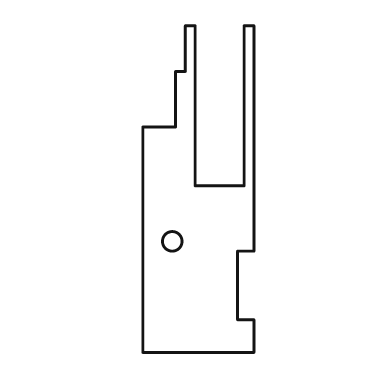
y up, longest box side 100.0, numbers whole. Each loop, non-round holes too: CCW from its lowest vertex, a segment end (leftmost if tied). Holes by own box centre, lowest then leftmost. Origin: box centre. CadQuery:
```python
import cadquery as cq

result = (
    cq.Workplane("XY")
    .moveTo(-17.0, -50.0)
    .lineTo(17.0, -50.0)
    .lineTo(17.0, -40.0)
    .lineTo(12.0, -40.0)
    .lineTo(12.0, -19.0)
    .lineTo(17.0, -19.0)
    .lineTo(17.0, 50.0)
    .lineTo(14.0, 50.0)
    .lineTo(14.0, 1.0)
    .lineTo(-1.0, 1.0)
    .lineTo(-1.0, 50.0)
    .lineTo(-4.0, 50.0)
    .lineTo(-4.0, 36.0)
    .lineTo(-7.0, 36.0)
    .lineTo(-7.0, 19.0)
    .lineTo(-17.0, 19.0)
    .close()
    .moveTo(-8.0, -16.0)
    .circle(3.0)
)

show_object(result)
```